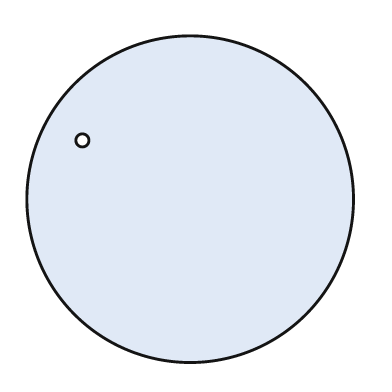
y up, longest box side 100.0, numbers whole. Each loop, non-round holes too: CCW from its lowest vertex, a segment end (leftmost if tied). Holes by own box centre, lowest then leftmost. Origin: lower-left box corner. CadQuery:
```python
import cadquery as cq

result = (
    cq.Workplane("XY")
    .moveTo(50.0, 50.0)
    .circle(50.0)
    .moveTo(17.0, 68.0)
    .circle(2.0)
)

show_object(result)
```